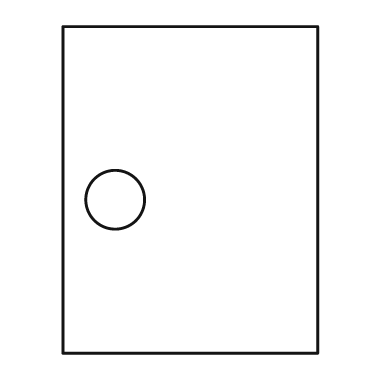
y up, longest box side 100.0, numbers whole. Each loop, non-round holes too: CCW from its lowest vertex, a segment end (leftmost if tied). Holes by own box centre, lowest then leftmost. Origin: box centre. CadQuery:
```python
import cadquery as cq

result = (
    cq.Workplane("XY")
    .moveTo(-39.0, -50.0)
    .lineTo(39.0, -50.0)
    .lineTo(39.0, 50.0)
    .lineTo(-39.0, 50.0)
    .close()
    .moveTo(-23.0, -3.0)
    .circle(9.0)
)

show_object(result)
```